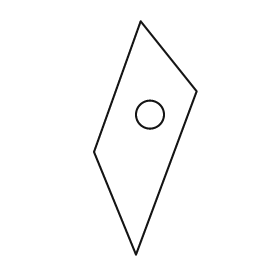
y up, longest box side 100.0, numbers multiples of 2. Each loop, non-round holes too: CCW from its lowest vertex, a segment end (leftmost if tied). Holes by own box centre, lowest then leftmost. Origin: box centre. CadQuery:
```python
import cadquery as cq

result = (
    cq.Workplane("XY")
    .moveTo(-4.0, -50.0)
    .lineTo(22.0, 20.0)
    .lineTo(-2.0, 50.0)
    .lineTo(-22.0, -6.0)
    .close()
    .moveTo(2.0, 10.0)
    .circle(6.0)
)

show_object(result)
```